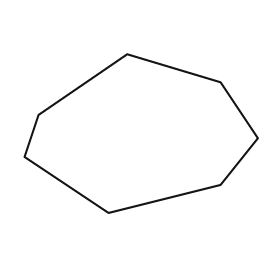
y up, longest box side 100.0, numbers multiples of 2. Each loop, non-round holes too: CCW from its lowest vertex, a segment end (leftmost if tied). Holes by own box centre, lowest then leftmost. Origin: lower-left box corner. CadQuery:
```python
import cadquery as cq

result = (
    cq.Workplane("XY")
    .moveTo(36.0, 0.0)
    .lineTo(84.0, 12.0)
    .lineTo(100.0, 32.0)
    .lineTo(84.0, 56.0)
    .lineTo(44.0, 68.0)
    .lineTo(6.0, 42.0)
    .lineTo(0.0, 24.0)
    .close()
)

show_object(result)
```